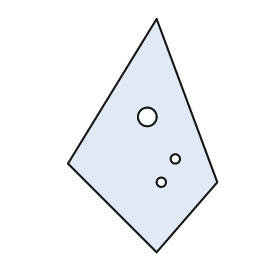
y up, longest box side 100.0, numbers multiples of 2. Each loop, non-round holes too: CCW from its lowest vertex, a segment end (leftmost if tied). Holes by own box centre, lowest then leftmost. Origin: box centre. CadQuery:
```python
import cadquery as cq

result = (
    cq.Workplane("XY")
    .moveTo(6.0, -50.0)
    .lineTo(32.0, -20.0)
    .lineTo(6.0, 50.0)
    .lineTo(-32.0, -12.0)
    .close()
    .moveTo(8.0, -20.0)
    .circle(2.0)
    .moveTo(14.0, -10.0)
    .circle(2.0)
    .moveTo(2.0, 8.0)
    .circle(4.0)
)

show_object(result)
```